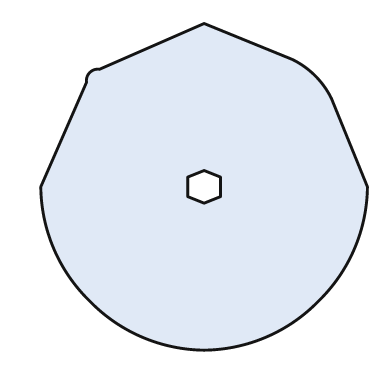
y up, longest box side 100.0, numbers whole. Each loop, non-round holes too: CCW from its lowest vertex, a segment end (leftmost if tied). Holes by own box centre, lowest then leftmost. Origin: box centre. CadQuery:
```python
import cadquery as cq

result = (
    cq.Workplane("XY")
    .moveTo(0.0, -50.0)
    .threePointArc((19.0, -46.0), (35.0, -35.0))
    .threePointArc((46.0, -19.0), (50.0, 0.0))
    .lineTo(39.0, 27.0)
    .threePointArc((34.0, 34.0), (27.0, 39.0))
    .lineTo(0.0, 50.0)
    .lineTo(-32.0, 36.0)
    .threePointArc((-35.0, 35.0), (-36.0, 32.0))
    .lineTo(-50.0, 0.0)
    .threePointArc((-46.0, -19.0), (-35.0, -35.0))
    .threePointArc((-19.0, -46.0), (0.0, -50.0))
    .close()
    .moveTo(0.0, -5.0)
    .lineTo(5.0, -3.0)
    .lineTo(5.0, 3.0)
    .lineTo(0.0, 5.0)
    .lineTo(-5.0, 3.0)
    .lineTo(-5.0, -3.0)
    .close()
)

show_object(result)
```